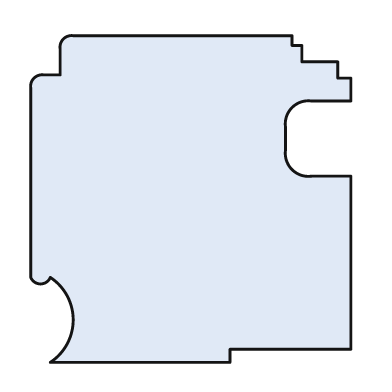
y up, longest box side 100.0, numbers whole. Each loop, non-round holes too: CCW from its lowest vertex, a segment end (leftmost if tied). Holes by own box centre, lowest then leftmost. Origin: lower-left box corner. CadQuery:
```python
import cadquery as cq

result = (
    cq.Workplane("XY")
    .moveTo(6.0, 0.0)
    .lineTo(61.0, 0.0)
    .lineTo(61.0, 4.0)
    .lineTo(98.0, 4.0)
    .lineTo(98.0, 57.0)
    .lineTo(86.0, 57.0)
    .threePointArc((80.0, 59.0), (78.0, 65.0))
    .lineTo(78.0, 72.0)
    .threePointArc((80.0, 78.0), (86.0, 80.0))
    .lineTo(98.0, 80.0)
    .lineTo(98.0, 87.0)
    .lineTo(94.0, 87.0)
    .lineTo(94.0, 92.0)
    .lineTo(83.0, 92.0)
    .lineTo(83.0, 97.0)
    .lineTo(80.0, 97.0)
    .lineTo(80.0, 100.0)
    .lineTo(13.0, 100.0)
    .threePointArc((10.0, 99.0), (9.0, 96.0))
    .lineTo(9.0, 88.0)
    .lineTo(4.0, 88.0)
    .threePointArc((1.0, 87.0), (0.0, 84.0))
    .lineTo(0.0, 26.0)
    .threePointArc((3.0, 24.0), (6.0, 26.0))
    .threePointArc((13.0, 13.0), (6.0, 0.0))
    .close()
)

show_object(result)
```